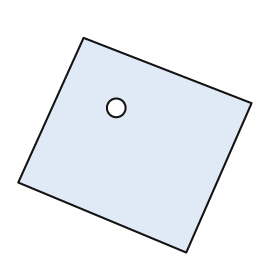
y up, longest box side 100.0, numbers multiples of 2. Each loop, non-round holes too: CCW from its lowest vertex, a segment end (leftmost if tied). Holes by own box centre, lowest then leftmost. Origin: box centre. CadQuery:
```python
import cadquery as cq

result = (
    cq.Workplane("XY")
    .moveTo(22.0, -46.0)
    .lineTo(50.0, 18.0)
    .lineTo(-22.0, 46.0)
    .lineTo(-50.0, -16.0)
    .close()
    .moveTo(-8.0, 16.0)
    .circle(4.0)
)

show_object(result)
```